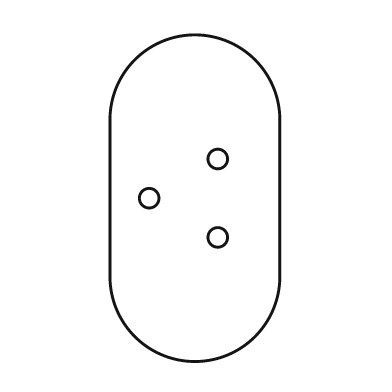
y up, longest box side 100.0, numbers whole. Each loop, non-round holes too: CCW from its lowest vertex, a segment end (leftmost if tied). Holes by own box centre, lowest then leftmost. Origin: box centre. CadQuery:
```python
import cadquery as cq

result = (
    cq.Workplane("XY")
    .moveTo(-26.0, -24.0)
    .threePointArc((0.0, -50.0), (26.0, -24.0))
    .lineTo(26.0, 24.0)
    .threePointArc((0.0, 50.0), (-26.0, 24.0))
    .close()
    .moveTo(7.0, -12.0)
    .circle(3.0)
    .moveTo(-14.0, 0.0)
    .circle(3.0)
    .moveTo(7.0, 12.0)
    .circle(3.0)
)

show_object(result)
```